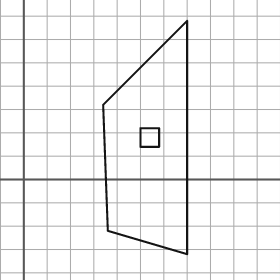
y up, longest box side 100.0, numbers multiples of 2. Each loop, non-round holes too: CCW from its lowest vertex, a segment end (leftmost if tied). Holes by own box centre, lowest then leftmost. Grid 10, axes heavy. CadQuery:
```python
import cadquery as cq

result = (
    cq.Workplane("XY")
    .moveTo(70.0, -32.0)
    .lineTo(70.0, 68.0)
    .lineTo(34.0, 32.0)
    .lineTo(36.0, -22.0)
    .close()
    .moveTo(50.0, 14.0)
    .lineTo(58.0, 14.0)
    .lineTo(58.0, 22.0)
    .lineTo(50.0, 22.0)
    .close()
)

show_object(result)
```